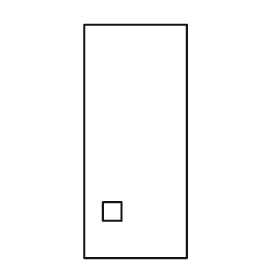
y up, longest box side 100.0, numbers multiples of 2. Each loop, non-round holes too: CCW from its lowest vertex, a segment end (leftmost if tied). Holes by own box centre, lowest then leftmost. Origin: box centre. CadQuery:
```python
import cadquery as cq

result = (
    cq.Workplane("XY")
    .moveTo(-22.0, -50.0)
    .lineTo(22.0, -50.0)
    .lineTo(22.0, 50.0)
    .lineTo(-22.0, 50.0)
    .close()
    .moveTo(-14.0, -34.0)
    .lineTo(-6.0, -34.0)
    .lineTo(-6.0, -26.0)
    .lineTo(-14.0, -26.0)
    .close()
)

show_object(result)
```